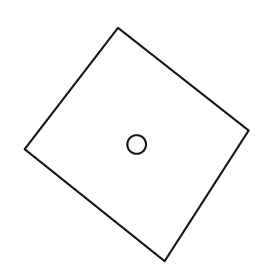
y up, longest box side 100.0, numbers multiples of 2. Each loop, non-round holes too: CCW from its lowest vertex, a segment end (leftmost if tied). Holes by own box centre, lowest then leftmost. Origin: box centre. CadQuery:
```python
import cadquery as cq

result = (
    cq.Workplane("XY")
    .moveTo(12.0, -50.0)
    .lineTo(48.0, 6.0)
    .lineTo(-8.0, 50.0)
    .lineTo(-48.0, -2.0)
    .close()
    .moveTo(0.0, 0.0)
    .circle(4.0)
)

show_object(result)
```